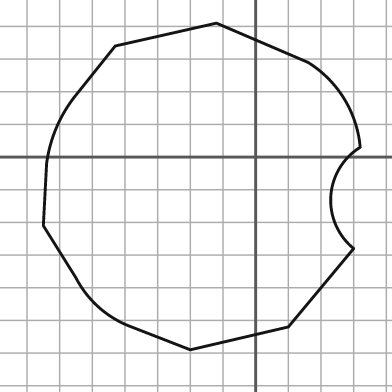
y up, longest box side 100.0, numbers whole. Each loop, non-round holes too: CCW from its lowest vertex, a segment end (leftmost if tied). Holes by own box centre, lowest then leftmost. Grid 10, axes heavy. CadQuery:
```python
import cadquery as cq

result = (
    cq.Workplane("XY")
    .moveTo(-20.0, -59.0)
    .lineTo(10.0, -52.0)
    .lineTo(30.0, -28.0)
    .threePointArc((23.0, -12.0), (32.0, 3.0))
    .threePointArc((27.0, 18.0), (16.0, 29.0))
    .lineTo(-12.0, 41.0)
    .lineTo(-43.0, 34.0)
    .lineTo(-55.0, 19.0)
    .threePointArc((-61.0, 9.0), (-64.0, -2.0))
    .lineTo(-65.0, -21.0)
    .lineTo(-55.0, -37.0)
    .threePointArc((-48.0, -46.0), (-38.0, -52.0))
    .close()
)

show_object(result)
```